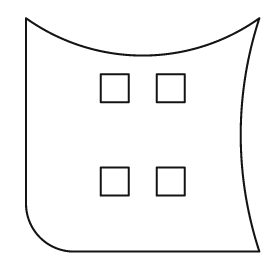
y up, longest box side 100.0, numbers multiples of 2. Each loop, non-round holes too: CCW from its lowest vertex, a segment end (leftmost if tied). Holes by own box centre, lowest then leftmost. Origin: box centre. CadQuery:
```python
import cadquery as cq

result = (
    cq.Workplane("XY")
    .moveTo(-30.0, -50.0)
    .lineTo(50.0, -50.0)
    .threePointArc((42.0, 0.0), (50.0, 50.0))
    .threePointArc((0.0, 34.0), (-50.0, 50.0))
    .lineTo(-50.0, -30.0)
    .threePointArc((-44.0, -44.0), (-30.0, -50.0))
    .close()
    .moveTo(-18.0, -26.0)
    .lineTo(-6.0, -26.0)
    .lineTo(-6.0, -14.0)
    .lineTo(-18.0, -14.0)
    .close()
    .moveTo(6.0, -26.0)
    .lineTo(18.0, -26.0)
    .lineTo(18.0, -14.0)
    .lineTo(6.0, -14.0)
    .close()
    .moveTo(-18.0, 14.0)
    .lineTo(-6.0, 14.0)
    .lineTo(-6.0, 26.0)
    .lineTo(-18.0, 26.0)
    .close()
    .moveTo(6.0, 14.0)
    .lineTo(18.0, 14.0)
    .lineTo(18.0, 26.0)
    .lineTo(6.0, 26.0)
    .close()
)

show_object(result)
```